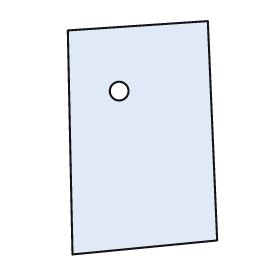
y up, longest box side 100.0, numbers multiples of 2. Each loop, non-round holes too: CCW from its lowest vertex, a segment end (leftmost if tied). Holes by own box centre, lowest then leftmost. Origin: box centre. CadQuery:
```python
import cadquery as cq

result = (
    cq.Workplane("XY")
    .moveTo(-30.0, -50.0)
    .lineTo(32.0, -44.0)
    .lineTo(28.0, 50.0)
    .lineTo(-32.0, 46.0)
    .close()
    .moveTo(-10.0, 20.0)
    .circle(4.0)
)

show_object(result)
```